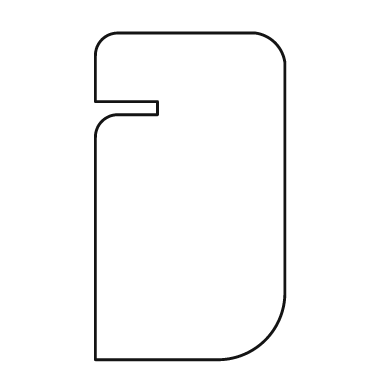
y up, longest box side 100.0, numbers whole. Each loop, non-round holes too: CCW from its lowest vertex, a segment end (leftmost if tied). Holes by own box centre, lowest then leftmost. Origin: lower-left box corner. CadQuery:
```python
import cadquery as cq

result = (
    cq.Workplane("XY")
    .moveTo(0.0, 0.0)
    .lineTo(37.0, 0.0)
    .threePointArc((52.0, 6.0), (58.0, 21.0))
    .lineTo(58.0, 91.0)
    .threePointArc((55.0, 97.0), (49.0, 100.0))
    .lineTo(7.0, 100.0)
    .threePointArc((2.0, 98.0), (0.0, 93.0))
    .lineTo(0.0, 79.0)
    .lineTo(19.0, 79.0)
    .lineTo(19.0, 75.0)
    .lineTo(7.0, 75.0)
    .threePointArc((2.0, 73.0), (0.0, 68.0))
    .close()
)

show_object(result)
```